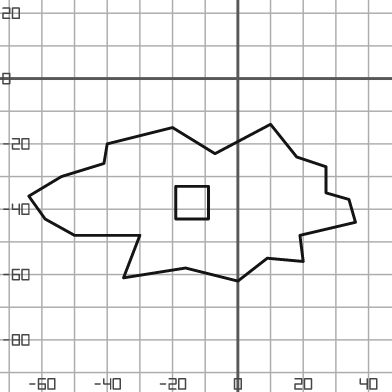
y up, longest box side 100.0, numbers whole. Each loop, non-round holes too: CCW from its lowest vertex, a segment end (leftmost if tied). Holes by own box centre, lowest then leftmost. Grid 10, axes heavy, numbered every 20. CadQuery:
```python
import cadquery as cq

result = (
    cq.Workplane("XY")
    .moveTo(0.0, -62.0)
    .lineTo(9.0, -55.0)
    .lineTo(20.0, -56.0)
    .lineTo(19.0, -48.0)
    .lineTo(36.0, -44.0)
    .lineTo(34.0, -37.0)
    .lineTo(27.0, -35.0)
    .lineTo(27.0, -27.0)
    .lineTo(18.0, -24.0)
    .lineTo(10.0, -14.0)
    .lineTo(-7.0, -23.0)
    .lineTo(-20.0, -15.0)
    .lineTo(-40.0, -20.0)
    .lineTo(-41.0, -26.0)
    .lineTo(-54.0, -30.0)
    .lineTo(-64.0, -36.0)
    .lineTo(-59.0, -43.0)
    .lineTo(-50.0, -48.0)
    .lineTo(-30.0, -48.0)
    .lineTo(-35.0, -61.0)
    .lineTo(-16.0, -58.0)
    .close()
    .moveTo(-19.0, -43.0)
    .lineTo(-9.0, -43.0)
    .lineTo(-9.0, -33.0)
    .lineTo(-19.0, -33.0)
    .close()
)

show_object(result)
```